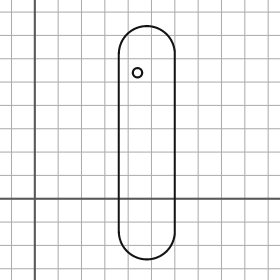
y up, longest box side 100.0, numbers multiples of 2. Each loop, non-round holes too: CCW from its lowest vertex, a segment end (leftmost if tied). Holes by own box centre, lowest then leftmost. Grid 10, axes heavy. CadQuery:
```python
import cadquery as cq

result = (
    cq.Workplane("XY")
    .moveTo(36.0, -14.0)
    .threePointArc((48.0, -26.0), (60.0, -14.0))
    .lineTo(60.0, 62.0)
    .threePointArc((48.0, 74.0), (36.0, 62.0))
    .close()
    .moveTo(44.0, 54.0)
    .circle(2.0)
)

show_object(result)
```